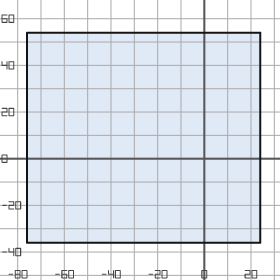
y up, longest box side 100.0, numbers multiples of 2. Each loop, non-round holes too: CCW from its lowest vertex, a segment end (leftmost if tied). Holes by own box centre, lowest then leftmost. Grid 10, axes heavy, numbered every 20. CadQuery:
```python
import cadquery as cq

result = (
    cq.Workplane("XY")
    .moveTo(-76.0, -36.0)
    .lineTo(24.0, -36.0)
    .lineTo(24.0, 54.0)
    .lineTo(-76.0, 54.0)
    .close()
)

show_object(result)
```